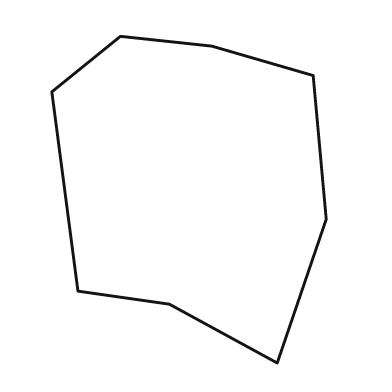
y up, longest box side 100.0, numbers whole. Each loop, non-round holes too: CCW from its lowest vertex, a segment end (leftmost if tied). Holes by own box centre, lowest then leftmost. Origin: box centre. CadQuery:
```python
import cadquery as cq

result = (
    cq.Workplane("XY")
    .moveTo(27.0, -50.0)
    .lineTo(42.0, -6.0)
    .lineTo(38.0, 38.0)
    .lineTo(7.0, 47.0)
    .lineTo(-21.0, 50.0)
    .lineTo(-42.0, 33.0)
    .lineTo(-34.0, -28.0)
    .lineTo(-6.0, -32.0)
    .close()
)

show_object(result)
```